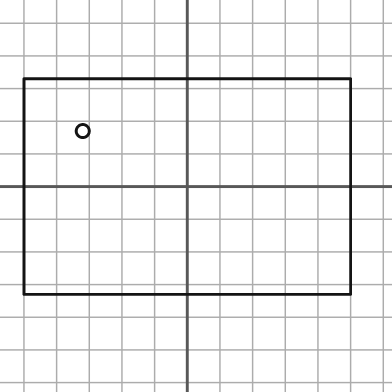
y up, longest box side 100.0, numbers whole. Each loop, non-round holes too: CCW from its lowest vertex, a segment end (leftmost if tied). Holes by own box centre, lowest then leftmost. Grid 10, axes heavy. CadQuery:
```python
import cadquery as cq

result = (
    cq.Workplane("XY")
    .moveTo(-50.0, -33.0)
    .lineTo(50.0, -33.0)
    .lineTo(50.0, 33.0)
    .lineTo(-50.0, 33.0)
    .close()
    .moveTo(-32.0, 17.0)
    .circle(2.0)
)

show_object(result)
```